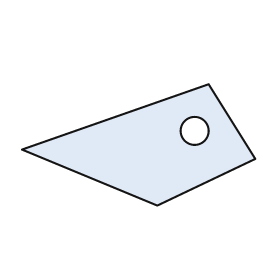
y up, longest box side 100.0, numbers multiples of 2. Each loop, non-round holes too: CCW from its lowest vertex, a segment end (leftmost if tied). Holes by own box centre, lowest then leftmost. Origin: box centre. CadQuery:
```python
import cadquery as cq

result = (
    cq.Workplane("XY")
    .moveTo(8.0, -26.0)
    .lineTo(50.0, -6.0)
    .lineTo(30.0, 26.0)
    .lineTo(-50.0, -2.0)
    .close()
    .moveTo(24.0, 6.0)
    .circle(6.0)
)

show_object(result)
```